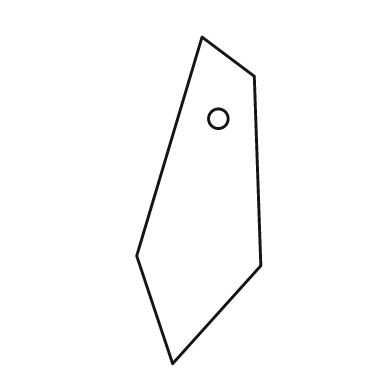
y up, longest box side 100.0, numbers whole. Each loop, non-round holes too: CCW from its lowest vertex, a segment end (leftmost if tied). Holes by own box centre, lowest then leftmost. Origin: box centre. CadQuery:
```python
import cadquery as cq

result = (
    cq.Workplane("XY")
    .moveTo(-8.0, -50.0)
    .lineTo(19.0, -20.0)
    .lineTo(17.0, 38.0)
    .lineTo(1.0, 50.0)
    .lineTo(-19.0, -17.0)
    .close()
    .moveTo(6.0, 25.0)
    .circle(3.0)
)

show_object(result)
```